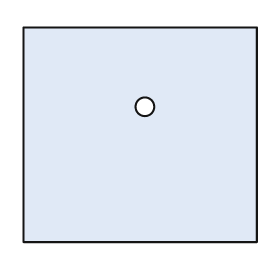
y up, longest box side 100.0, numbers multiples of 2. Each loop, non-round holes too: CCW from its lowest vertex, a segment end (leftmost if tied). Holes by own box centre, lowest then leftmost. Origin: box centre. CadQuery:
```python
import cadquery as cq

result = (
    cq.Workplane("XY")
    .moveTo(-50.0, -46.0)
    .lineTo(50.0, -46.0)
    .lineTo(50.0, 46.0)
    .lineTo(-50.0, 46.0)
    .close()
    .moveTo(2.0, 12.0)
    .circle(4.0)
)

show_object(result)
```